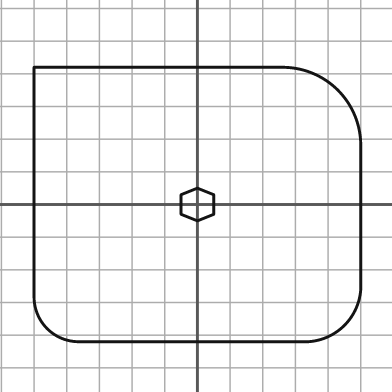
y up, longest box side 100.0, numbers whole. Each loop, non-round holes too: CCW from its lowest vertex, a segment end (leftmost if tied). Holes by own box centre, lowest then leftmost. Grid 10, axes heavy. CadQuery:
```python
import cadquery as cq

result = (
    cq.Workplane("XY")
    .moveTo(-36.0, -42.0)
    .lineTo(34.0, -42.0)
    .threePointArc((45.0, -37.0), (50.0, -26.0))
    .lineTo(50.0, 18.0)
    .threePointArc((43.0, 35.0), (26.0, 42.0))
    .lineTo(-50.0, 42.0)
    .lineTo(-50.0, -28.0)
    .threePointArc((-46.0, -38.0), (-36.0, -42.0))
    .close()
    .moveTo(0.0, -5.0)
    .lineTo(5.0, -3.0)
    .lineTo(5.0, 3.0)
    .lineTo(0.0, 5.0)
    .lineTo(-5.0, 3.0)
    .lineTo(-5.0, -3.0)
    .close()
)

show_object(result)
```